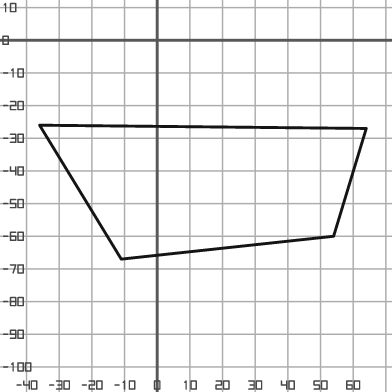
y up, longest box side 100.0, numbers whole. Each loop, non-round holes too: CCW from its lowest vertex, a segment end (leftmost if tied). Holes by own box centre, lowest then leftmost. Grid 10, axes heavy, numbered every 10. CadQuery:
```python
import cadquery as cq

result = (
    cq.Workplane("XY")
    .moveTo(-11.0, -67.0)
    .lineTo(54.0, -60.0)
    .lineTo(64.0, -27.0)
    .lineTo(-36.0, -26.0)
    .close()
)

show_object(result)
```